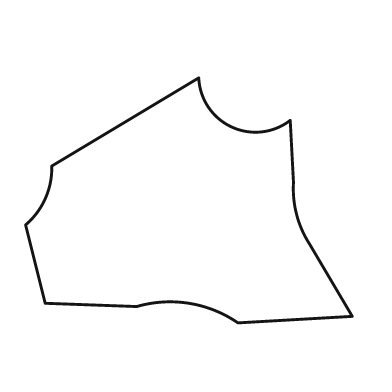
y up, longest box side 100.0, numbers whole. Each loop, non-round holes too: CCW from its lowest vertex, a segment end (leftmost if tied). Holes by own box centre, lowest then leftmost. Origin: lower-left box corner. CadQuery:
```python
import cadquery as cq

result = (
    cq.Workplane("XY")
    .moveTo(65.0, 0.0)
    .lineTo(100.0, 2.0)
    .lineTo(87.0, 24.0)
    .threePointArc((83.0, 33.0), (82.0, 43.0))
    .lineTo(81.0, 62.0)
    .threePointArc((63.0, 60.0), (53.0, 75.0))
    .lineTo(8.0, 48.0)
    .threePointArc((6.0, 38.0), (0.0, 30.0))
    .lineTo(6.0, 6.0)
    .lineTo(34.0, 5.0)
    .threePointArc((50.0, 6.0), (65.0, 0.0))
    .close()
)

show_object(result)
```